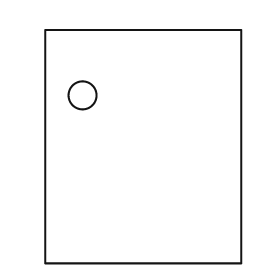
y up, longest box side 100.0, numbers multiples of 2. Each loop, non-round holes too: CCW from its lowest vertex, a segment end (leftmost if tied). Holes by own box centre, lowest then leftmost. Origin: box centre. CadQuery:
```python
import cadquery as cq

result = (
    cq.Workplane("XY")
    .moveTo(-42.0, -50.0)
    .lineTo(42.0, -50.0)
    .lineTo(42.0, 50.0)
    .lineTo(-42.0, 50.0)
    .close()
    .moveTo(-26.0, 22.0)
    .circle(6.0)
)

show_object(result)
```